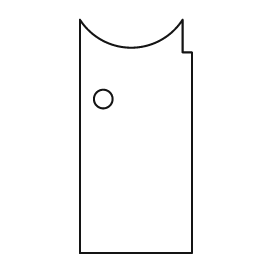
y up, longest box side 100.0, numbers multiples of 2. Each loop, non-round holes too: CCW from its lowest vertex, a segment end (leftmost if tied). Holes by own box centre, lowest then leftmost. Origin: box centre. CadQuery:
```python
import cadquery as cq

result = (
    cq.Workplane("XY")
    .moveTo(-24.0, -50.0)
    .lineTo(24.0, -50.0)
    .lineTo(24.0, 36.0)
    .lineTo(20.0, 36.0)
    .lineTo(20.0, 50.0)
    .threePointArc((-2.0, 38.0), (-24.0, 50.0))
    .close()
    .moveTo(-14.0, 16.0)
    .circle(4.0)
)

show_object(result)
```